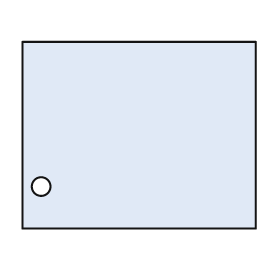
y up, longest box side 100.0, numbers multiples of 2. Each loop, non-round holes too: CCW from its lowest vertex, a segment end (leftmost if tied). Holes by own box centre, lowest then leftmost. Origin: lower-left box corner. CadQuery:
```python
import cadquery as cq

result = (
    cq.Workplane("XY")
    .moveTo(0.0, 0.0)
    .lineTo(100.0, 0.0)
    .lineTo(100.0, 80.0)
    .lineTo(0.0, 80.0)
    .close()
    .moveTo(8.0, 18.0)
    .circle(4.0)
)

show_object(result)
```